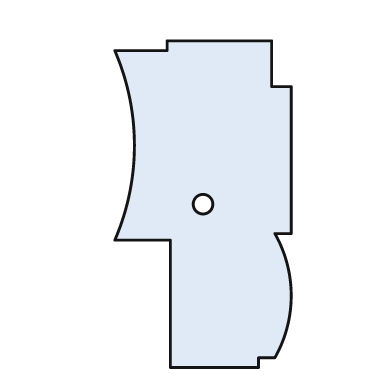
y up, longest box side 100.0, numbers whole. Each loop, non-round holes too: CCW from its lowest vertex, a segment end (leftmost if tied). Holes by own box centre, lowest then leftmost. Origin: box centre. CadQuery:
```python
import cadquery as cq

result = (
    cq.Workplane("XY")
    .moveTo(-10.0, -50.0)
    .lineTo(17.0, -50.0)
    .lineTo(17.0, -47.0)
    .lineTo(22.0, -47.0)
    .threePointArc((27.0, -28.0), (22.0, -9.0))
    .lineTo(27.0, -9.0)
    .lineTo(27.0, 36.0)
    .lineTo(21.0, 36.0)
    .lineTo(21.0, 50.0)
    .lineTo(-11.0, 50.0)
    .lineTo(-11.0, 47.0)
    .lineTo(-27.0, 47.0)
    .threePointArc((-21.0, 18.0), (-27.0, -11.0))
    .lineTo(-10.0, -11.0)
    .close()
    .moveTo(0.0, 0.0)
    .circle(3.0)
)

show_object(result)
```